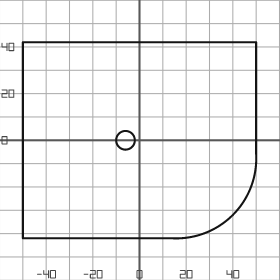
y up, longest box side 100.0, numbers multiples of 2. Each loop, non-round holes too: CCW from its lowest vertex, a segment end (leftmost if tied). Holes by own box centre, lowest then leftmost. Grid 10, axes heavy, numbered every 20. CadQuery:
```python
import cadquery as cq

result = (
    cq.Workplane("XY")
    .moveTo(-50.0, -42.0)
    .lineTo(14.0, -42.0)
    .threePointArc((40.0, -32.0), (50.0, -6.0))
    .lineTo(50.0, 42.0)
    .lineTo(-50.0, 42.0)
    .close()
    .moveTo(-6.0, 0.0)
    .circle(4.0)
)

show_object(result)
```